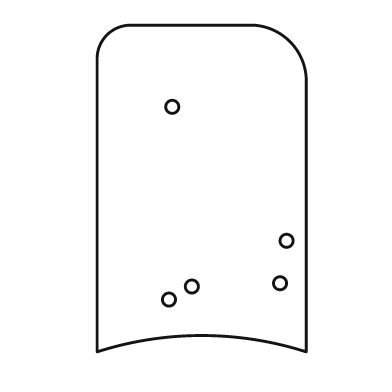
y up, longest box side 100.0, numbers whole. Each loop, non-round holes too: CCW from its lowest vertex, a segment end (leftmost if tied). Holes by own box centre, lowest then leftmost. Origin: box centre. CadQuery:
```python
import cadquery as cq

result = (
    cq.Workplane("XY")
    .moveTo(-32.0, -50.0)
    .threePointArc((0.0, -45.0), (32.0, -50.0))
    .lineTo(32.0, 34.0)
    .threePointArc((27.0, 45.0), (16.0, 50.0))
    .lineTo(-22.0, 50.0)
    .threePointArc((-29.0, 47.0), (-32.0, 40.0))
    .close()
    .moveTo(-10.0, -34.0)
    .circle(2.0)
    .moveTo(-3.0, -30.0)
    .circle(2.0)
    .moveTo(24.0, -29.0)
    .circle(2.0)
    .moveTo(26.0, -16.0)
    .circle(2.0)
    .moveTo(-9.0, 25.0)
    .circle(2.0)
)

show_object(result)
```